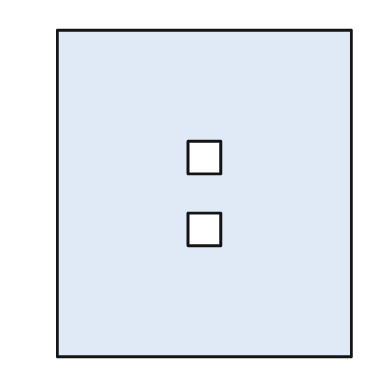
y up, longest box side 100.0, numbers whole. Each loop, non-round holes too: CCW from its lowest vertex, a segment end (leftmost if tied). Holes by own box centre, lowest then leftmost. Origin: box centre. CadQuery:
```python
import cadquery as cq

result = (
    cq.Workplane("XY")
    .moveTo(-45.0, -50.0)
    .lineTo(45.0, -50.0)
    .lineTo(45.0, 50.0)
    .lineTo(-45.0, 50.0)
    .close()
    .moveTo(-5.0, -16.0)
    .lineTo(5.0, -16.0)
    .lineTo(5.0, -6.0)
    .lineTo(-5.0, -6.0)
    .close()
    .moveTo(-5.0, 6.0)
    .lineTo(5.0, 6.0)
    .lineTo(5.0, 16.0)
    .lineTo(-5.0, 16.0)
    .close()
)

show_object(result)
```